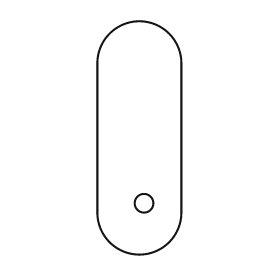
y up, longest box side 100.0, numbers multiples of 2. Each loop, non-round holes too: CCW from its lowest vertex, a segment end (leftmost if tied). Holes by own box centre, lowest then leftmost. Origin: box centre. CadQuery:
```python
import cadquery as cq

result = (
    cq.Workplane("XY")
    .moveTo(-18.0, -32.0)
    .threePointArc((0.0, -50.0), (18.0, -32.0))
    .lineTo(18.0, 32.0)
    .threePointArc((0.0, 50.0), (-18.0, 32.0))
    .close()
    .moveTo(2.0, -28.0)
    .circle(4.0)
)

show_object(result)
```